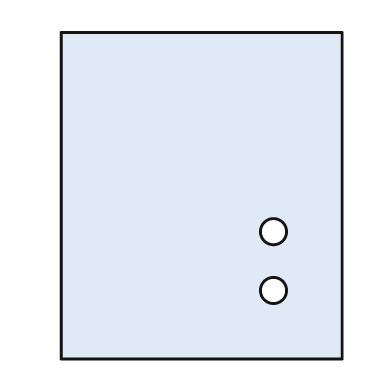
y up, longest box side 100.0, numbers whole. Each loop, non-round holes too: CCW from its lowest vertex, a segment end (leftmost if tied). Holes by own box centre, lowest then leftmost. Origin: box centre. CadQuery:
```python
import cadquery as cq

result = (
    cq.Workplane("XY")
    .moveTo(-43.0, -50.0)
    .lineTo(43.0, -50.0)
    .lineTo(43.0, 50.0)
    .lineTo(-43.0, 50.0)
    .close()
    .moveTo(22.0, -29.0)
    .circle(4.0)
    .moveTo(22.0, -11.0)
    .circle(4.0)
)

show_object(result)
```